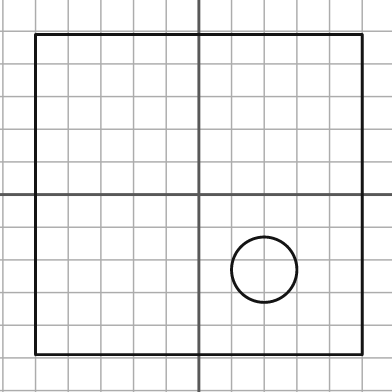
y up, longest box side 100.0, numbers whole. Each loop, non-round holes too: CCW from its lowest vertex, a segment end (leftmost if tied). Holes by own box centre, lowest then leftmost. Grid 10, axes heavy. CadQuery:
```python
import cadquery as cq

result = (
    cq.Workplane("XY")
    .moveTo(-50.0, -49.0)
    .lineTo(50.0, -49.0)
    .lineTo(50.0, 49.0)
    .lineTo(-50.0, 49.0)
    .close()
    .moveTo(20.0, -23.0)
    .circle(10.0)
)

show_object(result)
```